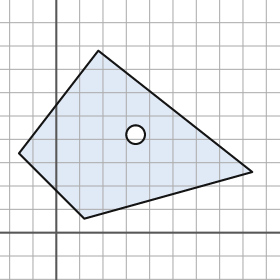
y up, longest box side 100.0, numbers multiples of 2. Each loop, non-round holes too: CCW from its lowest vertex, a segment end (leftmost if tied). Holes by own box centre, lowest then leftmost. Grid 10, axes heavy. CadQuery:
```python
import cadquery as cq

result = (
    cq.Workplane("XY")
    .moveTo(12.0, 6.0)
    .lineTo(84.0, 26.0)
    .lineTo(18.0, 78.0)
    .lineTo(-16.0, 34.0)
    .close()
    .moveTo(34.0, 42.0)
    .circle(4.0)
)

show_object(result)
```